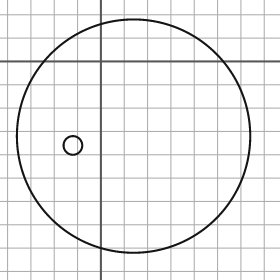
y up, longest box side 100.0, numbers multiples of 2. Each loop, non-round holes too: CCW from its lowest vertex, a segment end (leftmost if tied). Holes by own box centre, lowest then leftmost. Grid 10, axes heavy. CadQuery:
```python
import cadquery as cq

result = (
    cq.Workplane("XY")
    .moveTo(14.0, -32.0)
    .circle(50.0)
    .moveTo(-12.0, -36.0)
    .circle(4.0)
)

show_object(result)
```